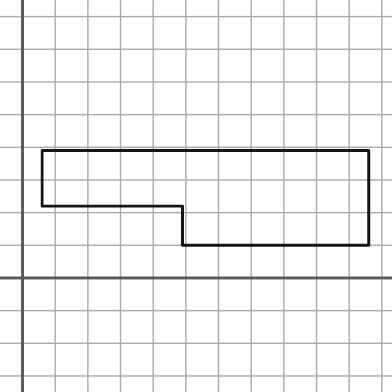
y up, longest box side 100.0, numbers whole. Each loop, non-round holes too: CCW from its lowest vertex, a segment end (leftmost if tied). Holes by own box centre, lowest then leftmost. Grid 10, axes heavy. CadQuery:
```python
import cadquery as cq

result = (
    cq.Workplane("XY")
    .moveTo(49.0, 10.0)
    .lineTo(106.0, 10.0)
    .lineTo(106.0, 39.0)
    .lineTo(6.0, 39.0)
    .lineTo(6.0, 22.0)
    .lineTo(49.0, 22.0)
    .close()
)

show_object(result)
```